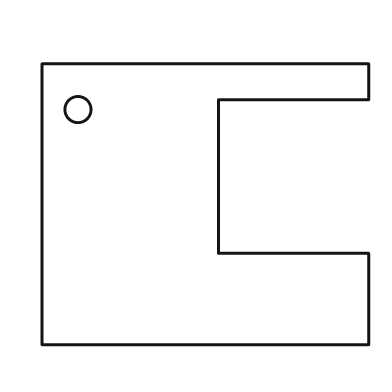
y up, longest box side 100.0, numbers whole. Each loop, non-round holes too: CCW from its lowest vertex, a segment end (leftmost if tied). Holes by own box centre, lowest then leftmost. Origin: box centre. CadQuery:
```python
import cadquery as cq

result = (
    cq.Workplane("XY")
    .moveTo(-50.0, -43.0)
    .lineTo(50.0, -43.0)
    .lineTo(50.0, -15.0)
    .lineTo(4.0, -15.0)
    .lineTo(4.0, 32.0)
    .lineTo(50.0, 32.0)
    .lineTo(50.0, 43.0)
    .lineTo(-50.0, 43.0)
    .close()
    .moveTo(-39.0, 29.0)
    .circle(4.0)
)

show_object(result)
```